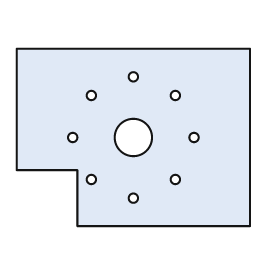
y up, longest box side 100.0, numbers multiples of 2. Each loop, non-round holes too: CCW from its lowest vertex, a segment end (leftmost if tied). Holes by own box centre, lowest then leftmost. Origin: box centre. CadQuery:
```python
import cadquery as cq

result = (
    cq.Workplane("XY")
    .moveTo(-24.0, -38.0)
    .lineTo(50.0, -38.0)
    .lineTo(50.0, 38.0)
    .lineTo(-50.0, 38.0)
    .lineTo(-50.0, -14.0)
    .lineTo(-24.0, -14.0)
    .close()
    .moveTo(0.0, -26.0)
    .circle(2.0)
    .moveTo(-18.0, -18.0)
    .circle(2.0)
    .moveTo(18.0, -18.0)
    .circle(2.0)
    .moveTo(-26.0, 0.0)
    .circle(2.0)
    .moveTo(0.0, 0.0)
    .circle(8.0)
    .moveTo(26.0, 0.0)
    .circle(2.0)
    .moveTo(-18.0, 18.0)
    .circle(2.0)
    .moveTo(18.0, 18.0)
    .circle(2.0)
    .moveTo(0.0, 26.0)
    .circle(2.0)
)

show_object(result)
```